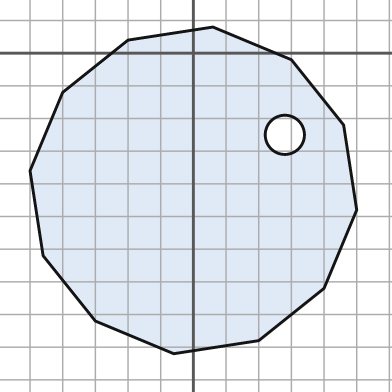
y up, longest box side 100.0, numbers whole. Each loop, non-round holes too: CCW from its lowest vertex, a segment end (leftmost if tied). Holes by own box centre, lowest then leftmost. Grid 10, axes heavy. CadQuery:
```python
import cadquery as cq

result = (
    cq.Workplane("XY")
    .moveTo(-6.0, -92.0)
    .lineTo(20.0, -88.0)
    .lineTo(40.0, -72.0)
    .lineTo(50.0, -48.0)
    .lineTo(46.0, -22.0)
    .lineTo(30.0, -2.0)
    .lineTo(6.0, 8.0)
    .lineTo(-20.0, 4.0)
    .lineTo(-40.0, -12.0)
    .lineTo(-50.0, -36.0)
    .lineTo(-46.0, -62.0)
    .lineTo(-30.0, -82.0)
    .close()
    .moveTo(28.0, -25.0)
    .circle(6.0)
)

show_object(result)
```